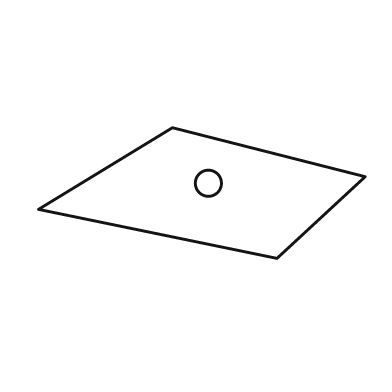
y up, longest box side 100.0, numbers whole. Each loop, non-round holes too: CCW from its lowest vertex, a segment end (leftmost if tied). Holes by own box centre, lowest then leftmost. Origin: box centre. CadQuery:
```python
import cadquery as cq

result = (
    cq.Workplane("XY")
    .moveTo(23.0, -20.0)
    .lineTo(50.0, 5.0)
    .lineTo(-9.0, 20.0)
    .lineTo(-50.0, -5.0)
    .close()
    .moveTo(2.0, 3.0)
    .circle(4.0)
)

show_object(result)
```